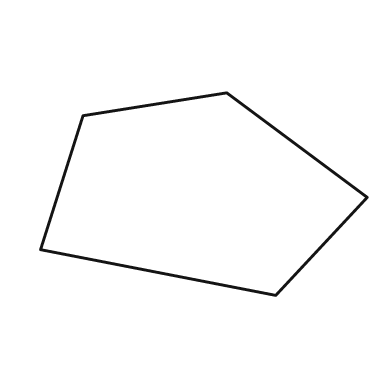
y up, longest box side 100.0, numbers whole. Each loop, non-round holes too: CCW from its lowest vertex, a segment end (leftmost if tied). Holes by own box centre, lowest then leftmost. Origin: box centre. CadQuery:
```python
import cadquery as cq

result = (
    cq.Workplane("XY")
    .moveTo(22.0, -31.0)
    .lineTo(50.0, -1.0)
    .lineTo(7.0, 31.0)
    .lineTo(-37.0, 24.0)
    .lineTo(-50.0, -17.0)
    .close()
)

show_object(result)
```